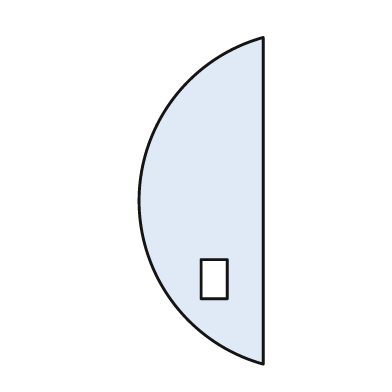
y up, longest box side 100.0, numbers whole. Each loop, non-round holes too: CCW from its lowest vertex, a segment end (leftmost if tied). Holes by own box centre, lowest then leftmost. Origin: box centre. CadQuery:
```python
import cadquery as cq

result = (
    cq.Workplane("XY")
    .moveTo(19.0, -50.0)
    .lineTo(19.0, 50.0)
    .threePointArc((-19.0, 0.0), (19.0, -50.0))
    .close()
    .moveTo(0.0, -30.0)
    .lineTo(8.0, -30.0)
    .lineTo(8.0, -18.0)
    .lineTo(0.0, -18.0)
    .close()
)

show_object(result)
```